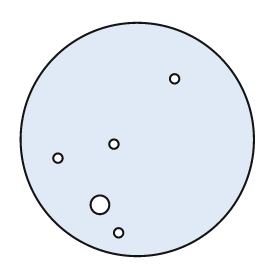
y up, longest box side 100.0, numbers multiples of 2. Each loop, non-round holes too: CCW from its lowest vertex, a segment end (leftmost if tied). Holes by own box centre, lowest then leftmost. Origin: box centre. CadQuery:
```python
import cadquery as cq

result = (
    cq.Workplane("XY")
    .moveTo(0.0, 0.0)
    .circle(50.0)
    .moveTo(-8.0, -40.0)
    .circle(2.0)
    .moveTo(-16.0, -28.0)
    .circle(4.0)
    .moveTo(-34.0, -8.0)
    .circle(2.0)
    .moveTo(-10.0, -2.0)
    .circle(2.0)
    .moveTo(16.0, 26.0)
    .circle(2.0)
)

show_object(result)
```